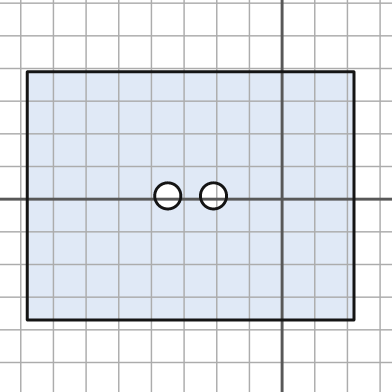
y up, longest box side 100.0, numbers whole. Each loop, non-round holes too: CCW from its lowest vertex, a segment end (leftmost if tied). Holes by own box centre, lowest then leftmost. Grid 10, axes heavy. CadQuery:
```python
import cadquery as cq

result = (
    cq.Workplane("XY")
    .moveTo(-78.0, -37.0)
    .lineTo(22.0, -37.0)
    .lineTo(22.0, 39.0)
    .lineTo(-78.0, 39.0)
    .close()
    .moveTo(-35.0, 1.0)
    .circle(4.0)
    .moveTo(-21.0, 1.0)
    .circle(4.0)
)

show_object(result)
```